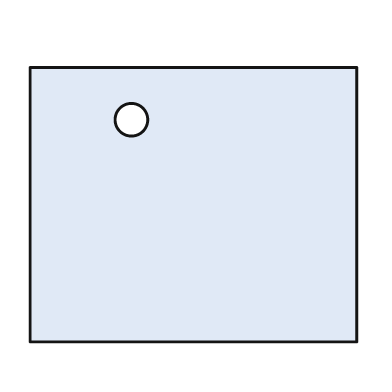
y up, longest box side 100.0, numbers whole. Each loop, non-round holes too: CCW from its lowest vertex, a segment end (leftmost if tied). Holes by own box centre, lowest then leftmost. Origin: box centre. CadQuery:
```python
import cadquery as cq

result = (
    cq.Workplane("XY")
    .moveTo(-50.0, -42.0)
    .lineTo(50.0, -42.0)
    .lineTo(50.0, 42.0)
    .lineTo(-50.0, 42.0)
    .close()
    .moveTo(-19.0, 26.0)
    .circle(5.0)
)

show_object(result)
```